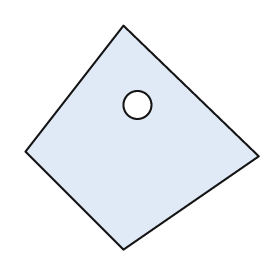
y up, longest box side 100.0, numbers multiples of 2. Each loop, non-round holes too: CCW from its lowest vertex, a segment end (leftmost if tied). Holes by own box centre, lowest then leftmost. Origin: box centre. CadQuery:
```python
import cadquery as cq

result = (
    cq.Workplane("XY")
    .moveTo(-8.0, -48.0)
    .lineTo(50.0, -8.0)
    .lineTo(-8.0, 48.0)
    .lineTo(-50.0, -6.0)
    .close()
    .moveTo(-2.0, 14.0)
    .circle(6.0)
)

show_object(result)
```